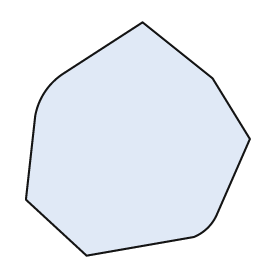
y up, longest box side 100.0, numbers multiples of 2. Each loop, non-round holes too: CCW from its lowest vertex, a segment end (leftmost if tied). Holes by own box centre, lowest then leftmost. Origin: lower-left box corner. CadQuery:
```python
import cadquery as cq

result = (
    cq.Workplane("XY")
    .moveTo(26.0, 0.0)
    .lineTo(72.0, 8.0)
    .threePointArc((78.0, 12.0), (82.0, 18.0))
    .lineTo(96.0, 50.0)
    .lineTo(80.0, 76.0)
    .lineTo(50.0, 100.0)
    .lineTo(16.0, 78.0)
    .threePointArc((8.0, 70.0), (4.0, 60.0))
    .lineTo(0.0, 24.0)
    .close()
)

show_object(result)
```